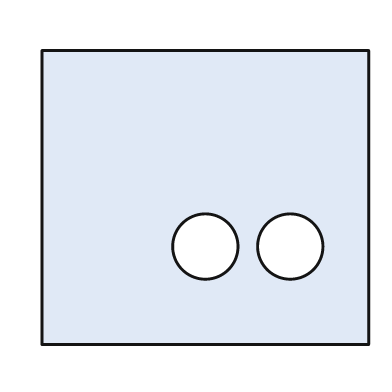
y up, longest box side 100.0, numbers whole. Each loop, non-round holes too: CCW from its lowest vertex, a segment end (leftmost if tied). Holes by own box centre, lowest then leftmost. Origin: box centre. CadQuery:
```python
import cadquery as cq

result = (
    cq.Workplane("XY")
    .moveTo(-50.0, -45.0)
    .lineTo(50.0, -45.0)
    .lineTo(50.0, 45.0)
    .lineTo(-50.0, 45.0)
    .close()
    .moveTo(0.0, -15.0)
    .circle(10.0)
    .moveTo(26.0, -15.0)
    .circle(10.0)
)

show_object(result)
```